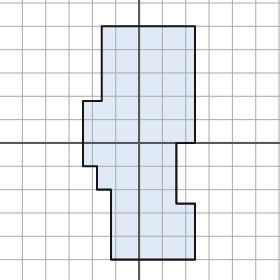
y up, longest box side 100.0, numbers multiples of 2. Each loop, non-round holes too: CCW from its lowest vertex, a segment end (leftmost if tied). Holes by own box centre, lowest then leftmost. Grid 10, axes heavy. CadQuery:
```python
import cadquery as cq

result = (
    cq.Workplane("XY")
    .moveTo(-12.0, -50.0)
    .lineTo(24.0, -50.0)
    .lineTo(24.0, -26.0)
    .lineTo(16.0, -26.0)
    .lineTo(16.0, 0.0)
    .lineTo(24.0, 0.0)
    .lineTo(24.0, 50.0)
    .lineTo(-16.0, 50.0)
    .lineTo(-16.0, 18.0)
    .lineTo(-24.0, 18.0)
    .lineTo(-24.0, -10.0)
    .lineTo(-18.0, -10.0)
    .lineTo(-18.0, -20.0)
    .lineTo(-12.0, -20.0)
    .close()
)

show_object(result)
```